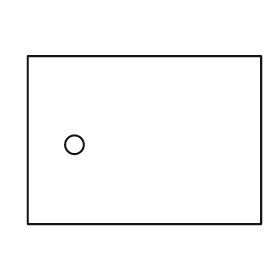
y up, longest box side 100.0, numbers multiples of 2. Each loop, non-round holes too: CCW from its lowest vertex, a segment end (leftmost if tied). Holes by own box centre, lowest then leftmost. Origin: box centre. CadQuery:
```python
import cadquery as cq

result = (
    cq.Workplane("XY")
    .moveTo(-50.0, -36.0)
    .lineTo(50.0, -36.0)
    .lineTo(50.0, 36.0)
    .lineTo(-50.0, 36.0)
    .close()
    .moveTo(-30.0, -2.0)
    .circle(4.0)
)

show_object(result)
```